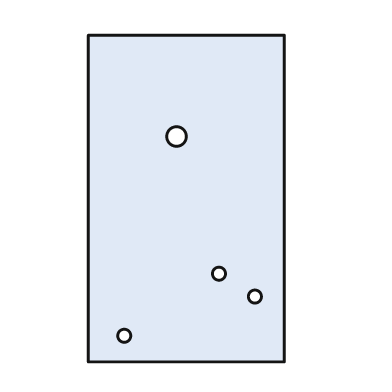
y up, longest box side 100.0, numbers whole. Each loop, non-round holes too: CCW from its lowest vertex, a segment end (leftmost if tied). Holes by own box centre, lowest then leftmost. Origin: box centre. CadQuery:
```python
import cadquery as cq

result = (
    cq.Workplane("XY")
    .moveTo(-30.0, -50.0)
    .lineTo(30.0, -50.0)
    .lineTo(30.0, 50.0)
    .lineTo(-30.0, 50.0)
    .close()
    .moveTo(-19.0, -42.0)
    .circle(2.0)
    .moveTo(21.0, -30.0)
    .circle(2.0)
    .moveTo(10.0, -23.0)
    .circle(2.0)
    .moveTo(-3.0, 19.0)
    .circle(3.0)
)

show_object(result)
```